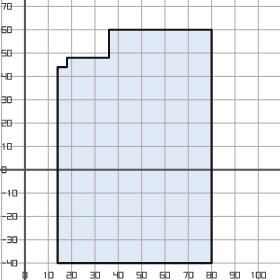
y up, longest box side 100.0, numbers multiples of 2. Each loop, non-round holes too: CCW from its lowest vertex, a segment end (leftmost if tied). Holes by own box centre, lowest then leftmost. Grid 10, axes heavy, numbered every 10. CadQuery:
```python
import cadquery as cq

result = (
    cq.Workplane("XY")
    .moveTo(14.0, -40.0)
    .lineTo(80.0, -40.0)
    .lineTo(80.0, 60.0)
    .lineTo(36.0, 60.0)
    .lineTo(36.0, 48.0)
    .lineTo(18.0, 48.0)
    .lineTo(18.0, 44.0)
    .lineTo(14.0, 44.0)
    .close()
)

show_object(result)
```